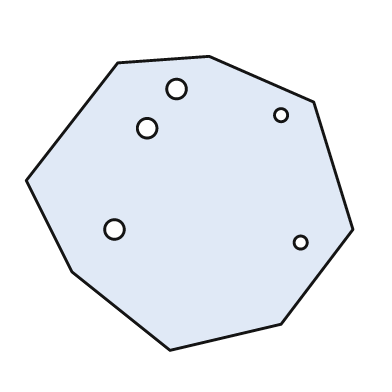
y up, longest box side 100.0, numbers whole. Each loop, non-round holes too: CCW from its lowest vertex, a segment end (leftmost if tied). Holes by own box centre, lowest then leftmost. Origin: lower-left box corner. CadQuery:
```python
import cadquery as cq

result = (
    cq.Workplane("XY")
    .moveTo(44.0, 0.0)
    .lineTo(78.0, 8.0)
    .lineTo(100.0, 37.0)
    .lineTo(88.0, 76.0)
    .lineTo(56.0, 90.0)
    .lineTo(28.0, 88.0)
    .lineTo(0.0, 52.0)
    .lineTo(14.0, 24.0)
    .close()
    .moveTo(84.0, 33.0)
    .circle(2.0)
    .moveTo(27.0, 37.0)
    .circle(3.0)
    .moveTo(37.0, 68.0)
    .circle(3.0)
    .moveTo(78.0, 72.0)
    .circle(2.0)
    .moveTo(46.0, 80.0)
    .circle(3.0)
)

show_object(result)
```